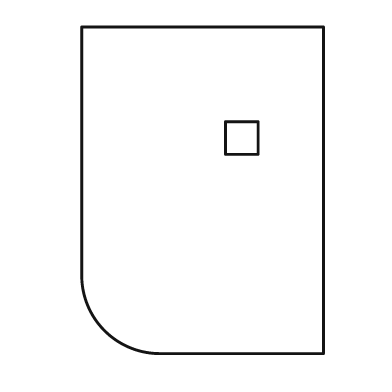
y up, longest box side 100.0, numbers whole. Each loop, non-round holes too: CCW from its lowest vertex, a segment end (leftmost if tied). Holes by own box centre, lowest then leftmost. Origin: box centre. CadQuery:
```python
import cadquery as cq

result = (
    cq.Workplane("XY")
    .moveTo(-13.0, -50.0)
    .lineTo(37.0, -50.0)
    .lineTo(37.0, 50.0)
    .lineTo(-37.0, 50.0)
    .lineTo(-37.0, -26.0)
    .threePointArc((-30.0, -43.0), (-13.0, -50.0))
    .close()
    .moveTo(7.0, 11.0)
    .lineTo(17.0, 11.0)
    .lineTo(17.0, 21.0)
    .lineTo(7.0, 21.0)
    .close()
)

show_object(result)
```